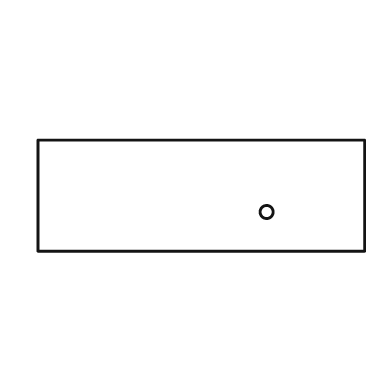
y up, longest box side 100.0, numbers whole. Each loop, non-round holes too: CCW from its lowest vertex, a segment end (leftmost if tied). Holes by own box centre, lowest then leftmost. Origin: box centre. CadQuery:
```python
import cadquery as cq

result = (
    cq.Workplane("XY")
    .moveTo(-50.0, -17.0)
    .lineTo(50.0, -17.0)
    .lineTo(50.0, 17.0)
    .lineTo(-50.0, 17.0)
    .close()
    .moveTo(20.0, -5.0)
    .circle(2.0)
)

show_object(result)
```